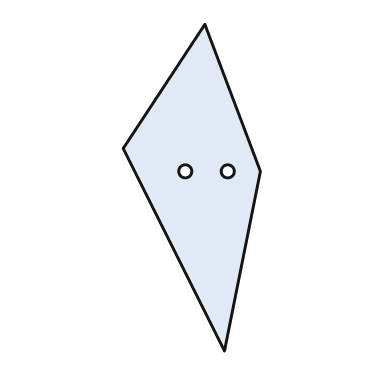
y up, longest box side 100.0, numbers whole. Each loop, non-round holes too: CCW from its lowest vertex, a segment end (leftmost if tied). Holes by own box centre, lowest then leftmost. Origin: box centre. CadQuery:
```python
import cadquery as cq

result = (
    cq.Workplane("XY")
    .moveTo(10.0, -50.0)
    .lineTo(21.0, 5.0)
    .lineTo(4.0, 50.0)
    .lineTo(-21.0, 12.0)
    .close()
    .moveTo(-2.0, 5.0)
    .circle(2.0)
    .moveTo(11.0, 5.0)
    .circle(2.0)
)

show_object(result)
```